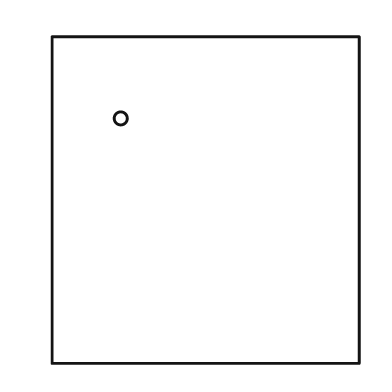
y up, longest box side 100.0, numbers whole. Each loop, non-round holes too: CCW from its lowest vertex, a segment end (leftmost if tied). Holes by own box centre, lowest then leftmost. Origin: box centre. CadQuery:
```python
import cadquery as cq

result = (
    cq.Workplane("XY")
    .moveTo(-47.0, -50.0)
    .lineTo(47.0, -50.0)
    .lineTo(47.0, 50.0)
    .lineTo(-47.0, 50.0)
    .close()
    .moveTo(-26.0, 25.0)
    .circle(2.0)
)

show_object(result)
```